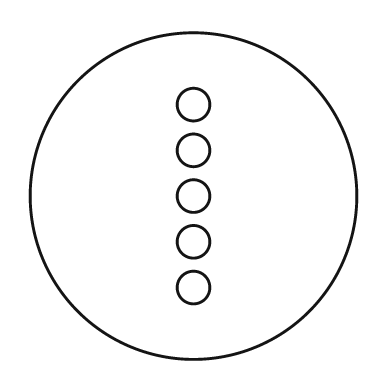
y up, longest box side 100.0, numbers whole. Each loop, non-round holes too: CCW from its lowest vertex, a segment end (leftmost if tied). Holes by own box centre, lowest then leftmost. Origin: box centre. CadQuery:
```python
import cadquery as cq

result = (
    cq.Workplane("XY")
    .moveTo(0.0, 0.0)
    .circle(50.0)
    .moveTo(0.0, -28.0)
    .circle(5.0)
    .moveTo(0.0, -14.0)
    .circle(5.0)
    .moveTo(0.0, 0.0)
    .circle(5.0)
    .moveTo(0.0, 14.0)
    .circle(5.0)
    .moveTo(0.0, 28.0)
    .circle(5.0)
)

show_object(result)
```